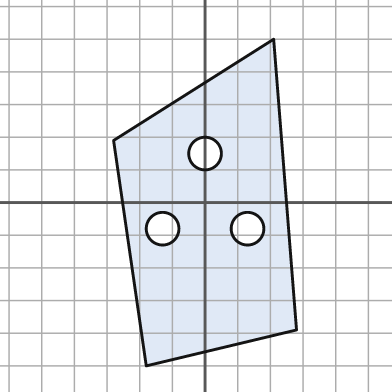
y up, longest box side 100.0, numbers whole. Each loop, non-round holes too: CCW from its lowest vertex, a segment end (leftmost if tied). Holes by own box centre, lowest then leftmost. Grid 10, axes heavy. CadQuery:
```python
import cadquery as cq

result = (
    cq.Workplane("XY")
    .moveTo(-18.0, -50.0)
    .lineTo(28.0, -39.0)
    .lineTo(21.0, 50.0)
    .lineTo(-28.0, 19.0)
    .close()
    .moveTo(-13.0, -8.0)
    .circle(5.0)
    .moveTo(13.0, -8.0)
    .circle(5.0)
    .moveTo(0.0, 15.0)
    .circle(5.0)
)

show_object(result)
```